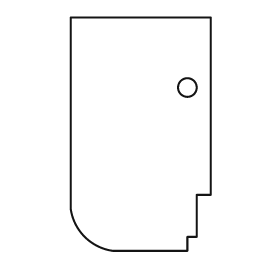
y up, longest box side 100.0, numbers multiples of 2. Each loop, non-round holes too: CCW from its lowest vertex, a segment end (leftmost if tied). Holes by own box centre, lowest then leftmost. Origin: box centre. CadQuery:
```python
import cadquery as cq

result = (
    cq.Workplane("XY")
    .moveTo(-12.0, -50.0)
    .lineTo(20.0, -50.0)
    .lineTo(20.0, -44.0)
    .lineTo(24.0, -44.0)
    .lineTo(24.0, -26.0)
    .lineTo(30.0, -26.0)
    .lineTo(30.0, 50.0)
    .lineTo(-30.0, 50.0)
    .lineTo(-30.0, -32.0)
    .threePointArc((-24.0, -44.0), (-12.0, -50.0))
    .close()
    .moveTo(20.0, 20.0)
    .circle(4.0)
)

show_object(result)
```